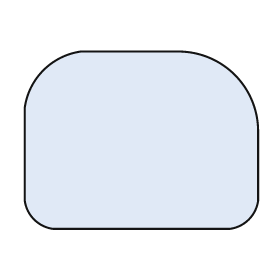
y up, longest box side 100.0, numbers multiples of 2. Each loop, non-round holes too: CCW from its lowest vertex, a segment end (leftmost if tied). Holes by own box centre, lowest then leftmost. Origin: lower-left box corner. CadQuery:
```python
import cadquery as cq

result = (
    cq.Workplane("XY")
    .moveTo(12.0, 0.0)
    .lineTo(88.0, 0.0)
    .threePointArc((96.0, 4.0), (100.0, 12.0))
    .lineTo(100.0, 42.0)
    .threePointArc((90.0, 66.0), (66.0, 76.0))
    .lineTo(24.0, 76.0)
    .threePointArc((8.0, 68.0), (0.0, 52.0))
    .lineTo(0.0, 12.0)
    .threePointArc((4.0, 4.0), (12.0, 0.0))
    .close()
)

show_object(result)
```